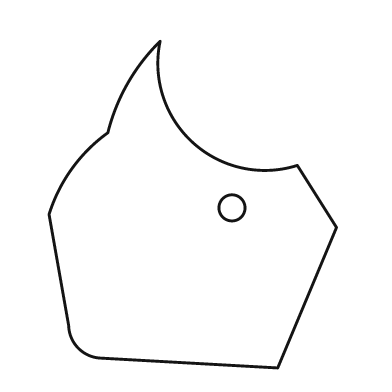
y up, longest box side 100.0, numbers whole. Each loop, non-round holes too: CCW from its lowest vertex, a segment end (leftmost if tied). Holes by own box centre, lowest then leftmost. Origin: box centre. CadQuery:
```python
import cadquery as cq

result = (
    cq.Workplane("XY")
    .moveTo(26.0, -50.0)
    .lineTo(44.0, -7.0)
    .lineTo(32.0, 12.0)
    .threePointArc((0.0, 19.0), (-10.0, 50.0))
    .threePointArc((-20.0, 37.0), (-26.0, 22.0))
    .threePointArc((-37.0, 11.0), (-44.0, -3.0))
    .lineTo(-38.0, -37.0)
    .threePointArc((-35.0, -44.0), (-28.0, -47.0))
    .close()
    .moveTo(12.0, -1.0)
    .circle(4.0)
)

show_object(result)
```